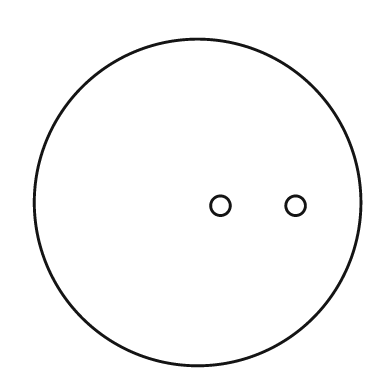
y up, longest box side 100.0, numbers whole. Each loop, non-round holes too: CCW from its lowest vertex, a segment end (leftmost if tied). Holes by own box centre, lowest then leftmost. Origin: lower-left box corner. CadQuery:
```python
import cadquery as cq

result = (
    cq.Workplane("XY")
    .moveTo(50.0, 50.0)
    .circle(50.0)
    .moveTo(57.0, 49.0)
    .circle(3.0)
    .moveTo(80.0, 49.0)
    .circle(3.0)
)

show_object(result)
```